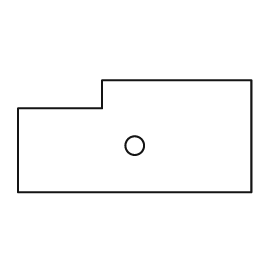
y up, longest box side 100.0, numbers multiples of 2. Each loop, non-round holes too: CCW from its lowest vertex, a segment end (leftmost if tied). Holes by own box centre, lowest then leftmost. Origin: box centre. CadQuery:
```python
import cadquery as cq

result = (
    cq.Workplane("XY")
    .moveTo(-50.0, -24.0)
    .lineTo(50.0, -24.0)
    .lineTo(50.0, 24.0)
    .lineTo(-14.0, 24.0)
    .lineTo(-14.0, 12.0)
    .lineTo(-50.0, 12.0)
    .close()
    .moveTo(0.0, -4.0)
    .circle(4.0)
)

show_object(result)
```